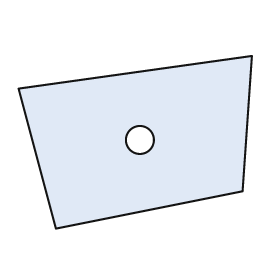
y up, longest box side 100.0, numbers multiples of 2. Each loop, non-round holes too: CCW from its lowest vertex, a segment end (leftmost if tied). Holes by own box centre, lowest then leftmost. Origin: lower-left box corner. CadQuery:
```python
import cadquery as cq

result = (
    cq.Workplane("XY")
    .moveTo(16.0, 0.0)
    .lineTo(96.0, 16.0)
    .lineTo(100.0, 74.0)
    .lineTo(0.0, 60.0)
    .close()
    .moveTo(52.0, 38.0)
    .circle(6.0)
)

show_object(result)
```